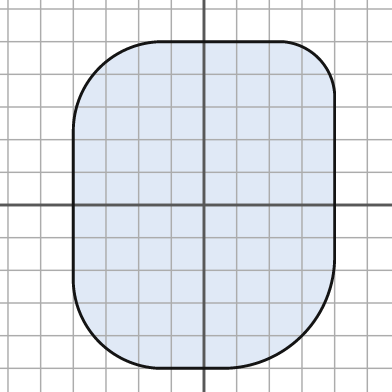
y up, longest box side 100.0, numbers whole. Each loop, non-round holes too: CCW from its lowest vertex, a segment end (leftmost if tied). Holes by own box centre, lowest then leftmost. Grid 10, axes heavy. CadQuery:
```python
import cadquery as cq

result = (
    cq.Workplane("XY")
    .moveTo(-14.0, -50.0)
    .lineTo(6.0, -50.0)
    .threePointArc((30.0, -40.0), (40.0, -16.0))
    .lineTo(40.0, 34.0)
    .threePointArc((35.0, 45.0), (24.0, 50.0))
    .lineTo(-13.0, 50.0)
    .threePointArc((-32.0, 42.0), (-40.0, 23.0))
    .lineTo(-40.0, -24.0)
    .threePointArc((-32.0, -42.0), (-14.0, -50.0))
    .close()
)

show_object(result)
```